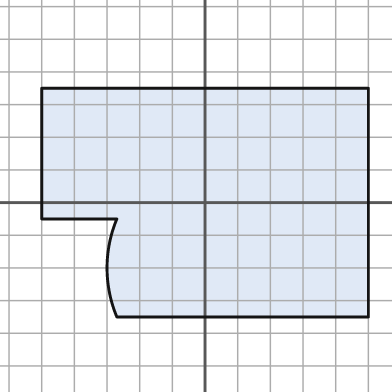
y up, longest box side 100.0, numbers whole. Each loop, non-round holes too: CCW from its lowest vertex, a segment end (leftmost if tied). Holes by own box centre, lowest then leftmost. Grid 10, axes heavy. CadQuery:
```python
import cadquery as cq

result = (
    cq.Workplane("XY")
    .moveTo(-27.0, -35.0)
    .lineTo(50.0, -35.0)
    .lineTo(50.0, 35.0)
    .lineTo(-50.0, 35.0)
    .lineTo(-50.0, -5.0)
    .lineTo(-27.0, -5.0)
    .threePointArc((-30.0, -20.0), (-27.0, -35.0))
    .close()
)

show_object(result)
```